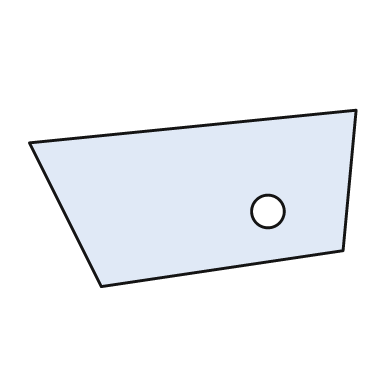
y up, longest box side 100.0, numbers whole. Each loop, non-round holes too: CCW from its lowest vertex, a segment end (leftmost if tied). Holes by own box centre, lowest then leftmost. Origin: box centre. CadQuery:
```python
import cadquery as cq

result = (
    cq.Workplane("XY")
    .moveTo(-28.0, -27.0)
    .lineTo(46.0, -16.0)
    .lineTo(50.0, 27.0)
    .lineTo(-50.0, 17.0)
    .close()
    .moveTo(23.0, -4.0)
    .circle(5.0)
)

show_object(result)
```